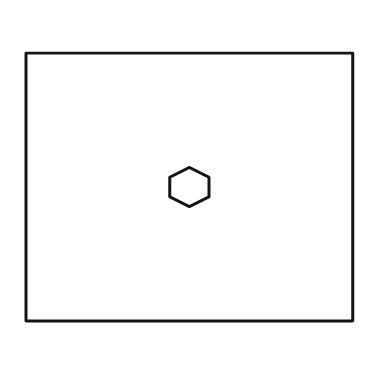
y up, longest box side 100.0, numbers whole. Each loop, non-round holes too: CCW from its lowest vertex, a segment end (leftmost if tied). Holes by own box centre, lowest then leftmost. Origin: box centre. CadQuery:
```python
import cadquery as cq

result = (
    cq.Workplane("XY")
    .moveTo(-50.0, -41.0)
    .lineTo(50.0, -41.0)
    .lineTo(50.0, 41.0)
    .lineTo(-50.0, 41.0)
    .close()
    .moveTo(0.0, -6.0)
    .lineTo(6.0, -3.0)
    .lineTo(6.0, 3.0)
    .lineTo(0.0, 6.0)
    .lineTo(-6.0, 3.0)
    .lineTo(-6.0, -3.0)
    .close()
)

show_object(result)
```